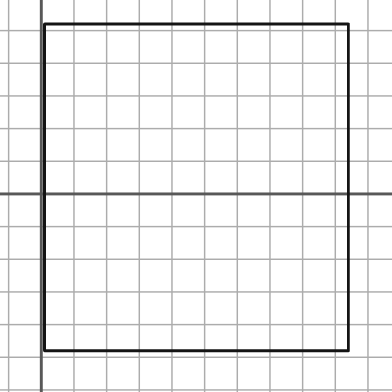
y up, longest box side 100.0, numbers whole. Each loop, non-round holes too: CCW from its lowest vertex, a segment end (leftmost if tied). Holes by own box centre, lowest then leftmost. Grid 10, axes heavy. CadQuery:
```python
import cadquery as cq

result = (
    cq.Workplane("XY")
    .moveTo(1.0, -48.0)
    .lineTo(94.0, -48.0)
    .lineTo(94.0, 52.0)
    .lineTo(1.0, 52.0)
    .close()
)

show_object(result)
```